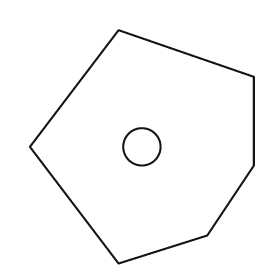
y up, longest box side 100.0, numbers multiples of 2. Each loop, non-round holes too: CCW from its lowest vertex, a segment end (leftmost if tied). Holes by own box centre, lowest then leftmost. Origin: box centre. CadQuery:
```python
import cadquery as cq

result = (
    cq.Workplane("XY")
    .moveTo(-10.0, -50.0)
    .lineTo(28.0, -38.0)
    .lineTo(48.0, -8.0)
    .lineTo(48.0, 30.0)
    .lineTo(-10.0, 50.0)
    .lineTo(-48.0, 0.0)
    .close()
    .moveTo(0.0, 0.0)
    .circle(8.0)
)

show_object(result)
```